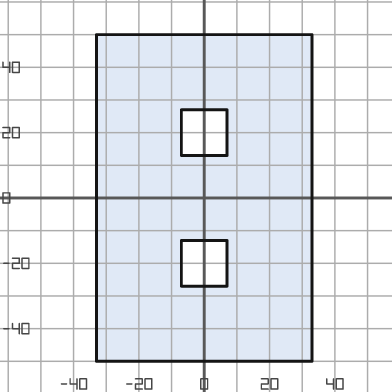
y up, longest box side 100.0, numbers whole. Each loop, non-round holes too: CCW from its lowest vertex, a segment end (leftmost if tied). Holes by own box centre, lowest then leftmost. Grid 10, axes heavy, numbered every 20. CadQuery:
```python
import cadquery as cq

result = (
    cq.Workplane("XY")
    .moveTo(-33.0, -50.0)
    .lineTo(33.0, -50.0)
    .lineTo(33.0, 50.0)
    .lineTo(-33.0, 50.0)
    .close()
    .moveTo(-7.0, -27.0)
    .lineTo(7.0, -27.0)
    .lineTo(7.0, -13.0)
    .lineTo(-7.0, -13.0)
    .close()
    .moveTo(-7.0, 13.0)
    .lineTo(7.0, 13.0)
    .lineTo(7.0, 27.0)
    .lineTo(-7.0, 27.0)
    .close()
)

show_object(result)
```